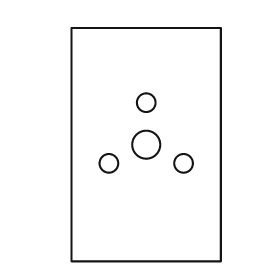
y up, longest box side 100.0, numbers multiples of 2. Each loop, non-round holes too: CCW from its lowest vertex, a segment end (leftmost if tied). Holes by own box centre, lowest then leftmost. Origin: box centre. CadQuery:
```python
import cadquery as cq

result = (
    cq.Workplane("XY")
    .moveTo(-32.0, -50.0)
    .lineTo(32.0, -50.0)
    .lineTo(32.0, 50.0)
    .lineTo(-32.0, 50.0)
    .close()
    .moveTo(-16.0, -8.0)
    .circle(4.0)
    .moveTo(16.0, -8.0)
    .circle(4.0)
    .moveTo(0.0, 0.0)
    .circle(6.0)
    .moveTo(0.0, 18.0)
    .circle(4.0)
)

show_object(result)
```